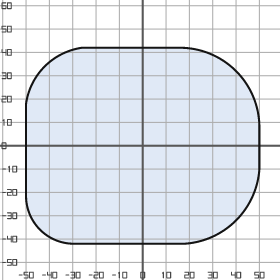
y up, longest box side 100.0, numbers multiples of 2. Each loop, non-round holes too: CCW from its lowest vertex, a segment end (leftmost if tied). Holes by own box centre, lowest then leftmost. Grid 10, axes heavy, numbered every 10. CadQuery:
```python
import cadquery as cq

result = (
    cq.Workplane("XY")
    .moveTo(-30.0, -42.0)
    .lineTo(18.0, -42.0)
    .threePointArc((40.0, -32.0), (50.0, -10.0))
    .lineTo(50.0, 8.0)
    .threePointArc((40.0, 32.0), (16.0, 42.0))
    .lineTo(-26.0, 42.0)
    .threePointArc((-42.0, 34.0), (-50.0, 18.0))
    .lineTo(-50.0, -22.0)
    .threePointArc((-44.0, -36.0), (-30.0, -42.0))
    .close()
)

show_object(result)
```